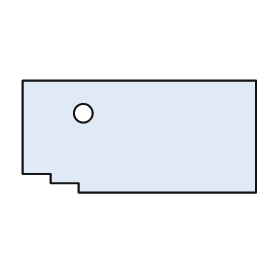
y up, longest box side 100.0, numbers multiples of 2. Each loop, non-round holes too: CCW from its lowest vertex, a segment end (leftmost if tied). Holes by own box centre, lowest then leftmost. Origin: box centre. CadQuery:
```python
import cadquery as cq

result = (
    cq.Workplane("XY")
    .moveTo(-26.0, -24.0)
    .lineTo(50.0, -24.0)
    .lineTo(50.0, 24.0)
    .lineTo(-50.0, 24.0)
    .lineTo(-50.0, -16.0)
    .lineTo(-38.0, -16.0)
    .lineTo(-38.0, -20.0)
    .lineTo(-26.0, -20.0)
    .close()
    .moveTo(-24.0, 10.0)
    .circle(4.0)
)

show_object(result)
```